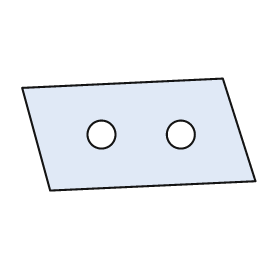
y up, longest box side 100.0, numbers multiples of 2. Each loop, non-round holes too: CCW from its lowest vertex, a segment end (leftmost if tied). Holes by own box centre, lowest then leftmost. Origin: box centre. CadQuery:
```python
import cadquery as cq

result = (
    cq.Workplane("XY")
    .moveTo(-38.0, -24.0)
    .lineTo(50.0, -20.0)
    .lineTo(36.0, 24.0)
    .lineTo(-50.0, 20.0)
    .close()
    .moveTo(-16.0, 0.0)
    .circle(6.0)
    .moveTo(18.0, 0.0)
    .circle(6.0)
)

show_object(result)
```